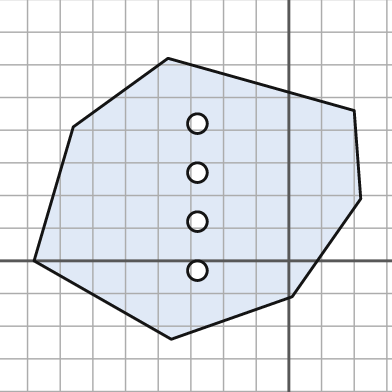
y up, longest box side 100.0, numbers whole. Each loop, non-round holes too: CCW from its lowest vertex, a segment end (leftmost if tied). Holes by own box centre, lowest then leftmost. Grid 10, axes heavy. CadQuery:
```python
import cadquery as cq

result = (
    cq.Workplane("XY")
    .moveTo(-36.0, -24.0)
    .lineTo(1.0, -11.0)
    .lineTo(22.0, 19.0)
    .lineTo(20.0, 46.0)
    .lineTo(-37.0, 62.0)
    .lineTo(-66.0, 41.0)
    .lineTo(-78.0, 0.0)
    .close()
    .moveTo(-28.0, -3.0)
    .circle(3.0)
    .moveTo(-28.0, 12.0)
    .circle(3.0)
    .moveTo(-28.0, 27.0)
    .circle(3.0)
    .moveTo(-28.0, 42.0)
    .circle(3.0)
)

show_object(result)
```